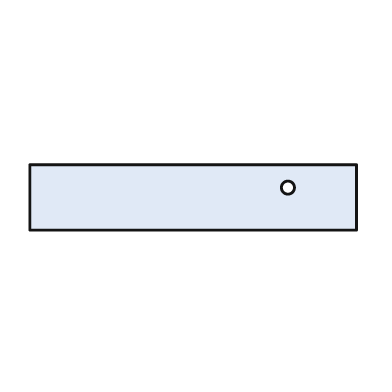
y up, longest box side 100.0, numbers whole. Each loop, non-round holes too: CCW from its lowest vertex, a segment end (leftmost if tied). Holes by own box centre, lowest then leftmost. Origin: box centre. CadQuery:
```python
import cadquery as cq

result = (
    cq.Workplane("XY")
    .moveTo(-50.0, -10.0)
    .lineTo(50.0, -10.0)
    .lineTo(50.0, 10.0)
    .lineTo(-50.0, 10.0)
    .close()
    .moveTo(29.0, 3.0)
    .circle(2.0)
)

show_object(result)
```